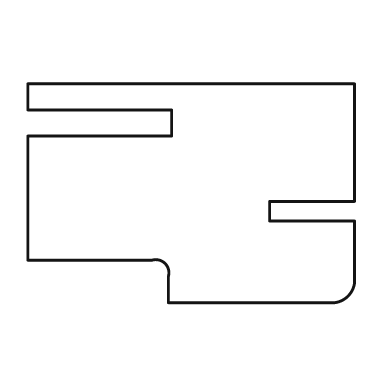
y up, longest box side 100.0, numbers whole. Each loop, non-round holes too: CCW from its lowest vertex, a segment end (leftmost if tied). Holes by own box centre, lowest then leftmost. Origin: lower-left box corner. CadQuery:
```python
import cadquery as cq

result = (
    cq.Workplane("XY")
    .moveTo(43.0, 0.0)
    .lineTo(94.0, 0.0)
    .threePointArc((98.0, 2.0), (100.0, 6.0))
    .lineTo(100.0, 25.0)
    .lineTo(74.0, 25.0)
    .lineTo(74.0, 31.0)
    .lineTo(100.0, 31.0)
    .lineTo(100.0, 67.0)
    .lineTo(0.0, 67.0)
    .lineTo(0.0, 59.0)
    .lineTo(44.0, 59.0)
    .lineTo(44.0, 51.0)
    .lineTo(0.0, 51.0)
    .lineTo(0.0, 13.0)
    .lineTo(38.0, 13.0)
    .threePointArc((42.0, 12.0), (43.0, 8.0))
    .close()
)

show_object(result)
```